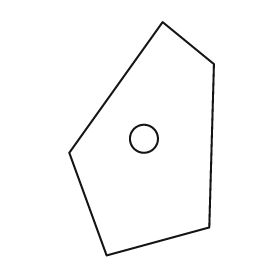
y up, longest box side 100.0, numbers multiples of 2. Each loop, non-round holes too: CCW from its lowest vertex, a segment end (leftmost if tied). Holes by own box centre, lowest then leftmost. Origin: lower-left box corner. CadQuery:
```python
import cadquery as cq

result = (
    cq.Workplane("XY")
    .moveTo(16.0, 0.0)
    .lineTo(60.0, 12.0)
    .lineTo(62.0, 82.0)
    .lineTo(40.0, 100.0)
    .lineTo(0.0, 44.0)
    .close()
    .moveTo(32.0, 50.0)
    .circle(6.0)
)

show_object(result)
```